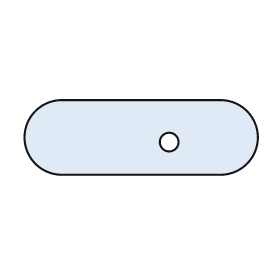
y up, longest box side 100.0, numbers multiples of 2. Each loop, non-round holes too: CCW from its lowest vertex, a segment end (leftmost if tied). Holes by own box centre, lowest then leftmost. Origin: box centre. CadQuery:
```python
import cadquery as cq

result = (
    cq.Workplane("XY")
    .moveTo(-34.0, -16.0)
    .lineTo(34.0, -16.0)
    .threePointArc((50.0, 0.0), (34.0, 16.0))
    .lineTo(-34.0, 16.0)
    .threePointArc((-50.0, 0.0), (-34.0, -16.0))
    .close()
    .moveTo(12.0, -2.0)
    .circle(4.0)
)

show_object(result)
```